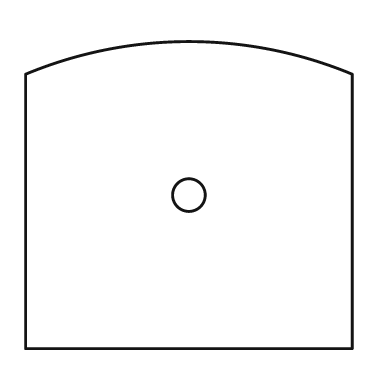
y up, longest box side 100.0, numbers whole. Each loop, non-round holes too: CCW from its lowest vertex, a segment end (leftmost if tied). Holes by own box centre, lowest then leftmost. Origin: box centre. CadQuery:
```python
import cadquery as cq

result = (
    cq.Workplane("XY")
    .moveTo(-50.0, -47.0)
    .lineTo(50.0, -47.0)
    .lineTo(50.0, 37.0)
    .threePointArc((0.0, 47.0), (-50.0, 37.0))
    .close()
    .moveTo(0.0, 0.0)
    .circle(5.0)
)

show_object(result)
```